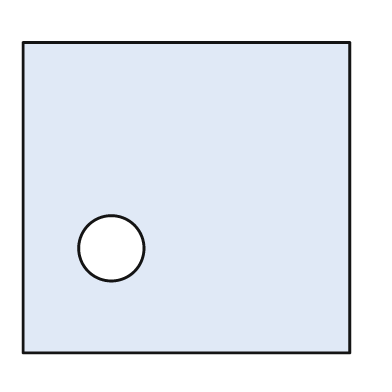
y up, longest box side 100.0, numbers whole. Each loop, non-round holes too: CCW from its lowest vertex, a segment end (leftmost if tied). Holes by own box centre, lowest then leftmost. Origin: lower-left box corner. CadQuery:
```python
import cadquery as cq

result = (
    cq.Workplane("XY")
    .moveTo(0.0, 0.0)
    .lineTo(100.0, 0.0)
    .lineTo(100.0, 95.0)
    .lineTo(0.0, 95.0)
    .close()
    .moveTo(27.0, 32.0)
    .circle(10.0)
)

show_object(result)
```